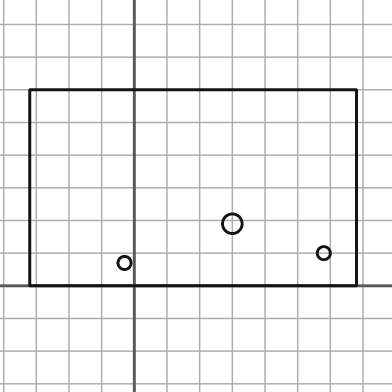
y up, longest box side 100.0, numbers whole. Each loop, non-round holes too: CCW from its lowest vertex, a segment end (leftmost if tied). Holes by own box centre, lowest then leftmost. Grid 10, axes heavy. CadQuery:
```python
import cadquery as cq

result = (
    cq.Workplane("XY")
    .moveTo(-32.0, 0.0)
    .lineTo(68.0, 0.0)
    .lineTo(68.0, 60.0)
    .lineTo(-32.0, 60.0)
    .close()
    .moveTo(-3.0, 7.0)
    .circle(2.0)
    .moveTo(58.0, 10.0)
    .circle(2.0)
    .moveTo(30.0, 19.0)
    .circle(3.0)
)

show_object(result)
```